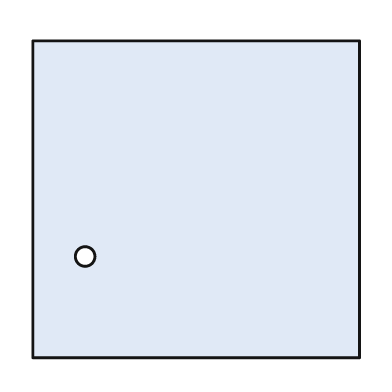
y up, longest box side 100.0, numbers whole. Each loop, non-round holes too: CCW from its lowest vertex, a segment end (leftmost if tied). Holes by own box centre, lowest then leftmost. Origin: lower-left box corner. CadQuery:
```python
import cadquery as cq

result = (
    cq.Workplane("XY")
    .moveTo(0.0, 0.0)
    .lineTo(100.0, 0.0)
    .lineTo(100.0, 97.0)
    .lineTo(0.0, 97.0)
    .close()
    .moveTo(16.0, 31.0)
    .circle(3.0)
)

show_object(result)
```